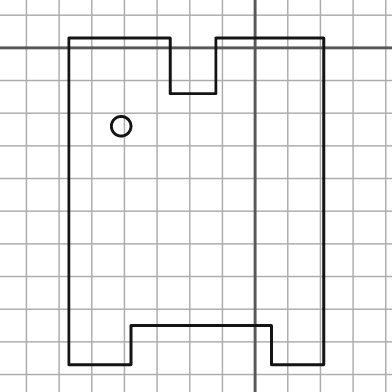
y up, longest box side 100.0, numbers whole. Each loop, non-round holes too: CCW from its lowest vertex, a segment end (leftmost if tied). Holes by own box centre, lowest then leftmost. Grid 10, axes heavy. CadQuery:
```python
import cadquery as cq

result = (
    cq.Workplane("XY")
    .moveTo(-57.0, -97.0)
    .lineTo(-38.0, -97.0)
    .lineTo(-38.0, -85.0)
    .lineTo(5.0, -85.0)
    .lineTo(5.0, -97.0)
    .lineTo(21.0, -97.0)
    .lineTo(21.0, 3.0)
    .lineTo(-12.0, 3.0)
    .lineTo(-12.0, -14.0)
    .lineTo(-26.0, -14.0)
    .lineTo(-26.0, 3.0)
    .lineTo(-57.0, 3.0)
    .close()
    .moveTo(-41.0, -24.0)
    .circle(3.0)
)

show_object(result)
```